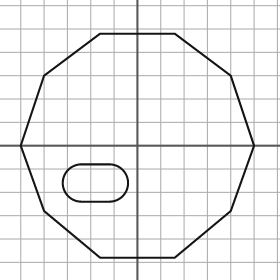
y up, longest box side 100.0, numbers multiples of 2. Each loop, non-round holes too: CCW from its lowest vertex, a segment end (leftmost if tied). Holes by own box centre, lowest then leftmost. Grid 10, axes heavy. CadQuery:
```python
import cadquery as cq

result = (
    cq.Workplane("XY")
    .moveTo(-16.0, -48.0)
    .lineTo(16.0, -48.0)
    .lineTo(40.0, -28.0)
    .lineTo(50.0, 0.0)
    .lineTo(40.0, 30.0)
    .lineTo(16.0, 48.0)
    .lineTo(-16.0, 48.0)
    .lineTo(-40.0, 30.0)
    .lineTo(-50.0, 0.0)
    .lineTo(-40.0, -28.0)
    .close()
    .moveTo(-24.0, -24.0)
    .lineTo(-12.0, -24.0)
    .threePointArc((-4.0, -16.0), (-12.0, -8.0))
    .lineTo(-24.0, -8.0)
    .threePointArc((-32.0, -16.0), (-24.0, -24.0))
    .close()
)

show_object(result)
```